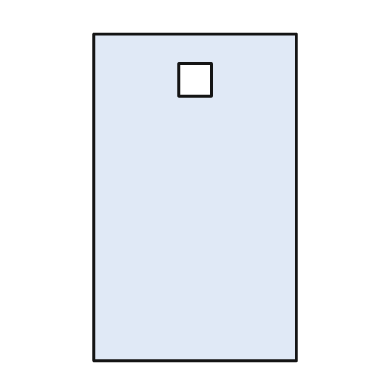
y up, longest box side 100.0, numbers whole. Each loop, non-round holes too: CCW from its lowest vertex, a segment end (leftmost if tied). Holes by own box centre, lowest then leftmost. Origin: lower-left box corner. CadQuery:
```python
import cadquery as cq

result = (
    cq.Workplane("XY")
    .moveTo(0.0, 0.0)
    .lineTo(62.0, 0.0)
    .lineTo(62.0, 100.0)
    .lineTo(0.0, 100.0)
    .close()
    .moveTo(26.0, 81.0)
    .lineTo(36.0, 81.0)
    .lineTo(36.0, 91.0)
    .lineTo(26.0, 91.0)
    .close()
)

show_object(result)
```